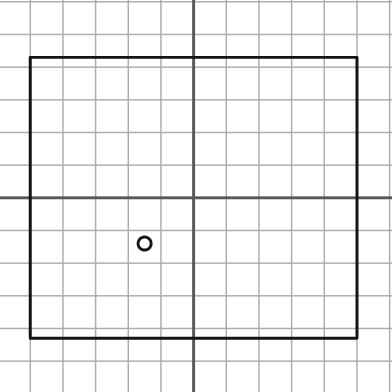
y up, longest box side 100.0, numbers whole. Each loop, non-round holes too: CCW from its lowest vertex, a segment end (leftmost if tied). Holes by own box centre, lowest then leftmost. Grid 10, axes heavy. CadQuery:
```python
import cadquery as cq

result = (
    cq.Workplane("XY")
    .moveTo(-50.0, -43.0)
    .lineTo(50.0, -43.0)
    .lineTo(50.0, 43.0)
    .lineTo(-50.0, 43.0)
    .close()
    .moveTo(-15.0, -14.0)
    .circle(2.0)
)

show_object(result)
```